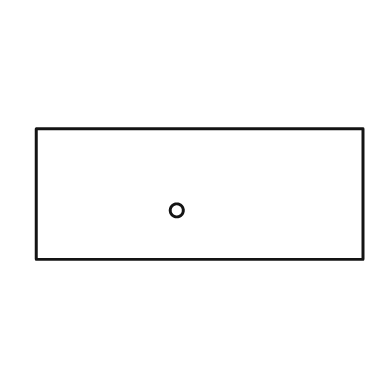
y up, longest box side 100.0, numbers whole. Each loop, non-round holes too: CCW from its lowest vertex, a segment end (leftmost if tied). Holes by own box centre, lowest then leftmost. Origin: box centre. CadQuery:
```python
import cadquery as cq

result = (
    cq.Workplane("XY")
    .moveTo(-50.0, -20.0)
    .lineTo(50.0, -20.0)
    .lineTo(50.0, 20.0)
    .lineTo(-50.0, 20.0)
    .close()
    .moveTo(-7.0, -5.0)
    .circle(2.0)
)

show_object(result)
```